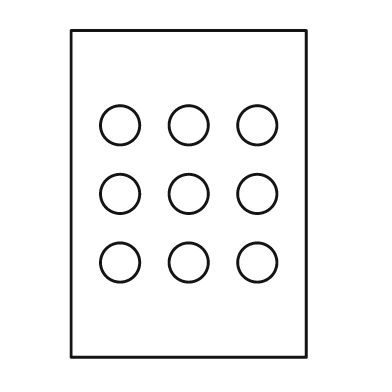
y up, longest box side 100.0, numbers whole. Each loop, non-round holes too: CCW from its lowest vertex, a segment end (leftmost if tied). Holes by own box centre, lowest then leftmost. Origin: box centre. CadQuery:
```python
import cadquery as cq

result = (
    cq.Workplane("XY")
    .moveTo(-36.0, -50.0)
    .lineTo(36.0, -50.0)
    .lineTo(36.0, 50.0)
    .lineTo(-36.0, 50.0)
    .close()
    .moveTo(-21.0, -21.0)
    .circle(6.0)
    .moveTo(0.0, -21.0)
    .circle(6.0)
    .moveTo(21.0, -21.0)
    .circle(6.0)
    .moveTo(-21.0, 0.0)
    .circle(6.0)
    .moveTo(0.0, 0.0)
    .circle(6.0)
    .moveTo(21.0, 0.0)
    .circle(6.0)
    .moveTo(-21.0, 21.0)
    .circle(6.0)
    .moveTo(0.0, 21.0)
    .circle(6.0)
    .moveTo(21.0, 21.0)
    .circle(6.0)
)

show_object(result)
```